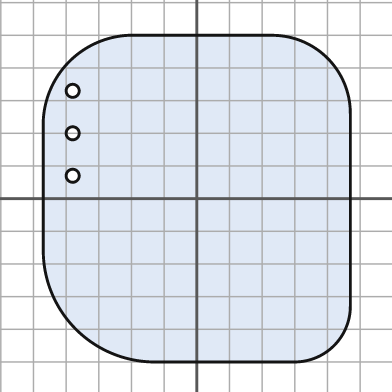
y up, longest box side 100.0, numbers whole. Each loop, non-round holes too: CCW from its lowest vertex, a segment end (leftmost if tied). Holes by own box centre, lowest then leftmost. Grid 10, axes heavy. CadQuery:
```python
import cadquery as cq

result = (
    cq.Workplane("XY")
    .moveTo(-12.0, -50.0)
    .lineTo(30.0, -50.0)
    .threePointArc((42.0, -45.0), (47.0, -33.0))
    .lineTo(47.0, 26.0)
    .threePointArc((40.0, 43.0), (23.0, 50.0))
    .lineTo(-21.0, 50.0)
    .threePointArc((-39.0, 42.0), (-47.0, 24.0))
    .lineTo(-47.0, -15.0)
    .threePointArc((-37.0, -40.0), (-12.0, -50.0))
    .close()
    .moveTo(-38.0, 7.0)
    .circle(2.0)
    .moveTo(-38.0, 20.0)
    .circle(2.0)
    .moveTo(-38.0, 33.0)
    .circle(2.0)
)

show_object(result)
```